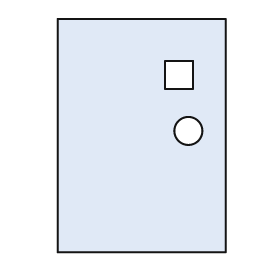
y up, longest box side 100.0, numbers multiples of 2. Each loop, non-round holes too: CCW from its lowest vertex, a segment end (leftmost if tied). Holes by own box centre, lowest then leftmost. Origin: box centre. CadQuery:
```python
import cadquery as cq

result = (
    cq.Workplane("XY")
    .moveTo(-36.0, -50.0)
    .lineTo(36.0, -50.0)
    .lineTo(36.0, 50.0)
    .lineTo(-36.0, 50.0)
    .close()
    .moveTo(20.0, 2.0)
    .circle(6.0)
    .moveTo(10.0, 20.0)
    .lineTo(22.0, 20.0)
    .lineTo(22.0, 32.0)
    .lineTo(10.0, 32.0)
    .close()
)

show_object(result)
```